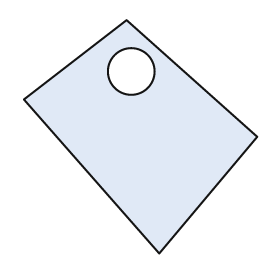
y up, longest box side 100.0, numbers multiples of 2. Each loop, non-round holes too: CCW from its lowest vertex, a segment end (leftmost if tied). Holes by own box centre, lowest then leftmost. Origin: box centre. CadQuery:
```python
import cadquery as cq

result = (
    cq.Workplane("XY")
    .moveTo(8.0, -50.0)
    .lineTo(50.0, 0.0)
    .lineTo(-6.0, 50.0)
    .lineTo(-50.0, 16.0)
    .close()
    .moveTo(-4.0, 28.0)
    .circle(10.0)
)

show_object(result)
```